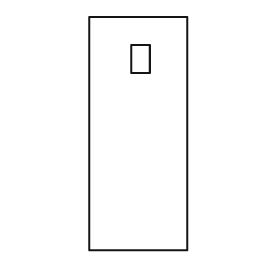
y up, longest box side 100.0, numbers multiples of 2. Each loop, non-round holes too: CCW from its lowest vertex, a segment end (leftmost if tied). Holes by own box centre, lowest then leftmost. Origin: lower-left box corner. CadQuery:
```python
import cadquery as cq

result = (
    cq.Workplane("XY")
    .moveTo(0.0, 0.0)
    .lineTo(42.0, 0.0)
    .lineTo(42.0, 100.0)
    .lineTo(0.0, 100.0)
    .close()
    .moveTo(18.0, 76.0)
    .lineTo(26.0, 76.0)
    .lineTo(26.0, 88.0)
    .lineTo(18.0, 88.0)
    .close()
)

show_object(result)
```